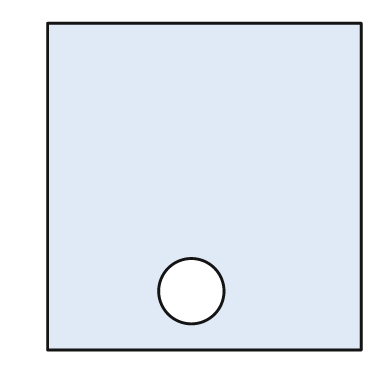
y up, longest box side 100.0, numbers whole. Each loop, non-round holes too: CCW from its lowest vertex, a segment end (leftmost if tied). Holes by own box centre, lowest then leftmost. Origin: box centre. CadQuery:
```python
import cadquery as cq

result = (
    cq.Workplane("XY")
    .moveTo(-48.0, -50.0)
    .lineTo(48.0, -50.0)
    .lineTo(48.0, 50.0)
    .lineTo(-48.0, 50.0)
    .close()
    .moveTo(-4.0, -32.0)
    .circle(10.0)
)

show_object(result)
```